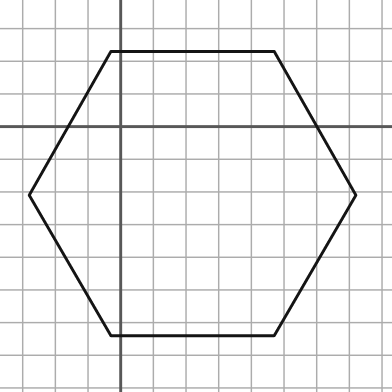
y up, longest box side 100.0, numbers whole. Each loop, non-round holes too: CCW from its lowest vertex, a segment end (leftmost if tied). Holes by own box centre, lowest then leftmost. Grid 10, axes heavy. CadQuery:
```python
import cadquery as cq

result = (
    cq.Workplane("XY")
    .moveTo(-3.0, -64.0)
    .lineTo(47.0, -64.0)
    .lineTo(72.0, -21.0)
    .lineTo(47.0, 23.0)
    .lineTo(-3.0, 23.0)
    .lineTo(-28.0, -21.0)
    .close()
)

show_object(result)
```